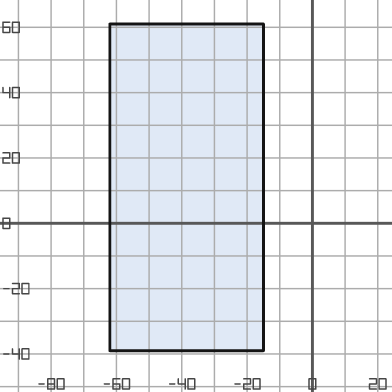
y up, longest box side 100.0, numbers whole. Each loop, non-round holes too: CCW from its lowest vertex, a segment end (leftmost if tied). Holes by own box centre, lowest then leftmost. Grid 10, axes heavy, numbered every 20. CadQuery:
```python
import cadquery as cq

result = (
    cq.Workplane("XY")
    .moveTo(-62.0, -39.0)
    .lineTo(-15.0, -39.0)
    .lineTo(-15.0, 61.0)
    .lineTo(-62.0, 61.0)
    .close()
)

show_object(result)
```